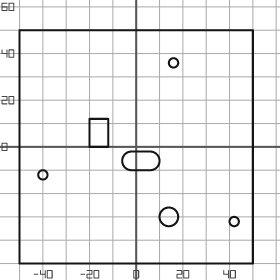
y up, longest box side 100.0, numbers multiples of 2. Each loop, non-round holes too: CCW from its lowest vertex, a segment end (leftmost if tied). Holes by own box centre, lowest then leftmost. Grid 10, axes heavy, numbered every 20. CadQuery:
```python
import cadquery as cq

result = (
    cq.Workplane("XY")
    .moveTo(-50.0, -50.0)
    .lineTo(50.0, -50.0)
    .lineTo(50.0, 50.0)
    .lineTo(-50.0, 50.0)
    .close()
    .moveTo(42.0, -32.0)
    .circle(2.0)
    .moveTo(14.0, -30.0)
    .circle(4.0)
    .moveTo(-40.0, -12.0)
    .circle(2.0)
    .moveTo(-2.0, -10.0)
    .lineTo(6.0, -10.0)
    .threePointArc((10.0, -6.0), (6.0, -2.0))
    .lineTo(-2.0, -2.0)
    .threePointArc((-6.0, -6.0), (-2.0, -10.0))
    .close()
    .moveTo(-20.0, 0.0)
    .lineTo(-12.0, 0.0)
    .lineTo(-12.0, 12.0)
    .lineTo(-20.0, 12.0)
    .close()
    .moveTo(16.0, 36.0)
    .circle(2.0)
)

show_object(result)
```